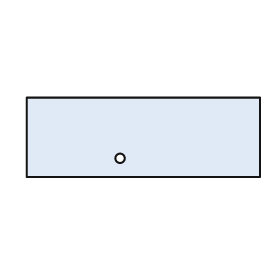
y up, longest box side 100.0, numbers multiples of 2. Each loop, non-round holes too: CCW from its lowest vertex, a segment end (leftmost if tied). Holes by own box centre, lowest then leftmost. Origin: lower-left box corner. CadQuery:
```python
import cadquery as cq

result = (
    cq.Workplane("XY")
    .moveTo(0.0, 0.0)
    .lineTo(100.0, 0.0)
    .lineTo(100.0, 34.0)
    .lineTo(0.0, 34.0)
    .close()
    .moveTo(40.0, 8.0)
    .circle(2.0)
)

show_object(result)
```